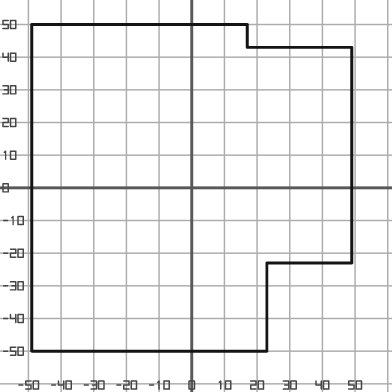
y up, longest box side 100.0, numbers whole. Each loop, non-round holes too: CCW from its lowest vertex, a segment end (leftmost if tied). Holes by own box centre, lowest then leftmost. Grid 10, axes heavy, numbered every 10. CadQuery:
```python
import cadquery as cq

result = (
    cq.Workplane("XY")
    .moveTo(-49.0, -50.0)
    .lineTo(23.0, -50.0)
    .lineTo(23.0, -23.0)
    .lineTo(49.0, -23.0)
    .lineTo(49.0, 43.0)
    .lineTo(17.0, 43.0)
    .lineTo(17.0, 50.0)
    .lineTo(-49.0, 50.0)
    .close()
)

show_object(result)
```